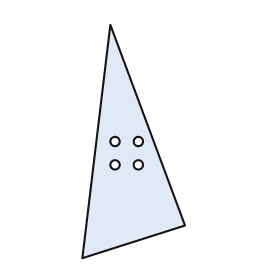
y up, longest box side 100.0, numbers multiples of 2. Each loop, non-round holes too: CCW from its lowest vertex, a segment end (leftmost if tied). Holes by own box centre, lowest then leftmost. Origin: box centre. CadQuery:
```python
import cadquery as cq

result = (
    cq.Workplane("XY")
    .moveTo(-22.0, -50.0)
    .lineTo(22.0, -36.0)
    .lineTo(-10.0, 50.0)
    .close()
    .moveTo(-8.0, -10.0)
    .circle(2.0)
    .moveTo(2.0, -10.0)
    .circle(2.0)
    .moveTo(-8.0, 0.0)
    .circle(2.0)
    .moveTo(2.0, 0.0)
    .circle(2.0)
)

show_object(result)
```